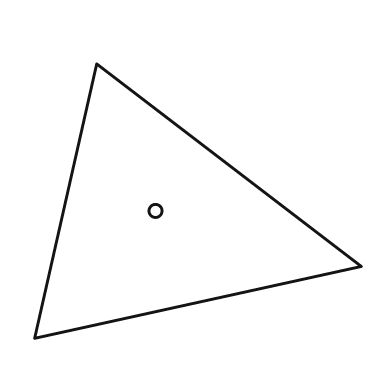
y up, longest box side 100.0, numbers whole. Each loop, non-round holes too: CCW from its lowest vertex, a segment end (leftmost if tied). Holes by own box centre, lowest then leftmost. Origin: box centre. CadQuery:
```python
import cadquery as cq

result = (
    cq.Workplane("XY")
    .moveTo(-50.0, -42.0)
    .lineTo(50.0, -20.0)
    .lineTo(-31.0, 42.0)
    .close()
    .moveTo(-13.0, -3.0)
    .circle(2.0)
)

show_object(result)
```